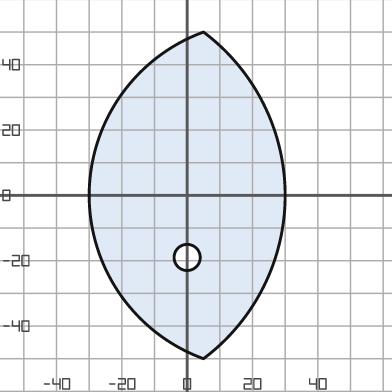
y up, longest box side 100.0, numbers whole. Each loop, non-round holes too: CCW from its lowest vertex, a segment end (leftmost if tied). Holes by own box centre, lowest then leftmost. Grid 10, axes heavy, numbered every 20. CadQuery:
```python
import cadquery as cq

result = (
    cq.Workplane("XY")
    .moveTo(5.0, -50.0)
    .threePointArc((30.0, 0.0), (5.0, 50.0))
    .threePointArc((-30.0, 0.0), (5.0, -50.0))
    .close()
    .moveTo(0.0, -19.0)
    .circle(4.0)
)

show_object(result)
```